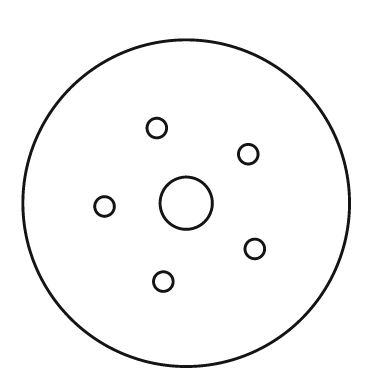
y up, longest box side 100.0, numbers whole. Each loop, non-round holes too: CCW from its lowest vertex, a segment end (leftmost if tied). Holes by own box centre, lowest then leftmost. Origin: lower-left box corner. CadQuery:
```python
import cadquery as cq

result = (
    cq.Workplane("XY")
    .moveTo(50.0, 50.0)
    .circle(50.0)
    .moveTo(43.0, 26.0)
    .circle(3.0)
    .moveTo(71.0, 36.0)
    .circle(3.0)
    .moveTo(25.0, 49.0)
    .circle(3.0)
    .moveTo(50.0, 50.0)
    .circle(8.0)
    .moveTo(69.0, 65.0)
    .circle(3.0)
    .moveTo(41.0, 73.0)
    .circle(3.0)
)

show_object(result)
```